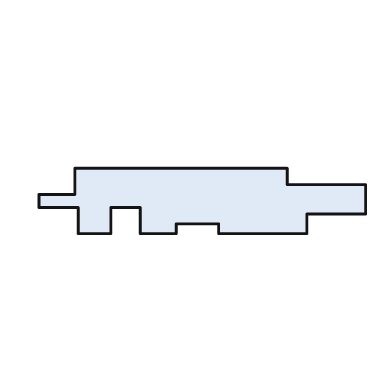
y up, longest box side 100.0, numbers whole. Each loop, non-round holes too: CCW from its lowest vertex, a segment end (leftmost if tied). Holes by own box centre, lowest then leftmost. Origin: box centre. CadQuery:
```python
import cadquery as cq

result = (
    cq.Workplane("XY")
    .moveTo(-38.0, -10.0)
    .lineTo(-28.0, -10.0)
    .lineTo(-28.0, -2.0)
    .lineTo(-19.0, -2.0)
    .lineTo(-19.0, -10.0)
    .lineTo(-8.0, -10.0)
    .lineTo(-8.0, -7.0)
    .lineTo(5.0, -7.0)
    .lineTo(5.0, -10.0)
    .lineTo(32.0, -10.0)
    .lineTo(32.0, -4.0)
    .lineTo(50.0, -4.0)
    .lineTo(50.0, 5.0)
    .lineTo(26.0, 5.0)
    .lineTo(26.0, 10.0)
    .lineTo(-39.0, 10.0)
    .lineTo(-39.0, 2.0)
    .lineTo(-50.0, 2.0)
    .lineTo(-50.0, -2.0)
    .lineTo(-38.0, -2.0)
    .close()
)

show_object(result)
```